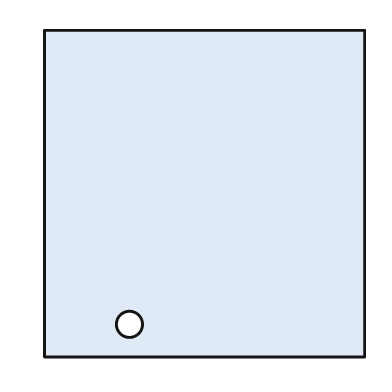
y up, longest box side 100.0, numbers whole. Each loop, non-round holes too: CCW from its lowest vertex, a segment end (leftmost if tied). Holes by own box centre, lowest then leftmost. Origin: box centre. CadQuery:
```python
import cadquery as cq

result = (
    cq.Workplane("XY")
    .moveTo(-49.0, -50.0)
    .lineTo(49.0, -50.0)
    .lineTo(49.0, 50.0)
    .lineTo(-49.0, 50.0)
    .close()
    .moveTo(-23.0, -40.0)
    .circle(4.0)
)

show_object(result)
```